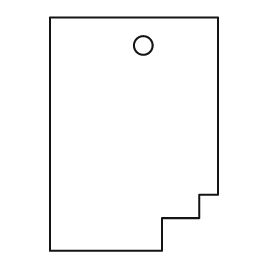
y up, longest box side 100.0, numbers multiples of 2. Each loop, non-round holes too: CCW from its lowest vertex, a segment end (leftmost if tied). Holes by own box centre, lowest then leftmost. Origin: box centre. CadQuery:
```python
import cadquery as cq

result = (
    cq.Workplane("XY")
    .moveTo(-36.0, -50.0)
    .lineTo(12.0, -50.0)
    .lineTo(12.0, -36.0)
    .lineTo(28.0, -36.0)
    .lineTo(28.0, -26.0)
    .lineTo(36.0, -26.0)
    .lineTo(36.0, 50.0)
    .lineTo(-36.0, 50.0)
    .close()
    .moveTo(4.0, 38.0)
    .circle(4.0)
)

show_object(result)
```